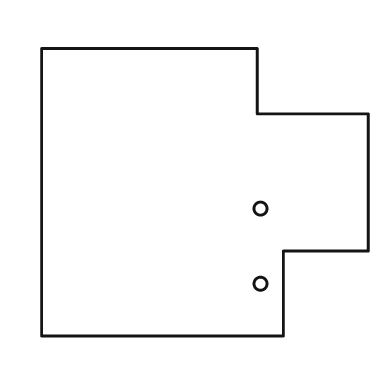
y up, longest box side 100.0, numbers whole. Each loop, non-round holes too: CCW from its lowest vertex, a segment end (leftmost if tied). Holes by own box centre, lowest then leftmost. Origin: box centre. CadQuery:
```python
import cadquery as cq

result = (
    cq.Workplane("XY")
    .moveTo(-50.0, -44.0)
    .lineTo(24.0, -44.0)
    .lineTo(24.0, -18.0)
    .lineTo(50.0, -18.0)
    .lineTo(50.0, 24.0)
    .lineTo(16.0, 24.0)
    .lineTo(16.0, 44.0)
    .lineTo(-50.0, 44.0)
    .close()
    .moveTo(17.0, -28.0)
    .circle(2.0)
    .moveTo(17.0, -5.0)
    .circle(2.0)
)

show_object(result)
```